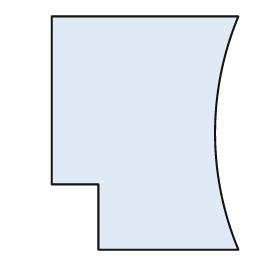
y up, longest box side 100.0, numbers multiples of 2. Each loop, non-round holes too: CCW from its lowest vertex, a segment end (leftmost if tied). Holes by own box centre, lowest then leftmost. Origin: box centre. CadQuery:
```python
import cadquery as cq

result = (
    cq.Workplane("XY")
    .moveTo(-20.0, -50.0)
    .lineTo(40.0, -50.0)
    .threePointArc((30.0, 0.0), (40.0, 50.0))
    .lineTo(-40.0, 50.0)
    .lineTo(-40.0, -22.0)
    .lineTo(-20.0, -22.0)
    .close()
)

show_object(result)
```